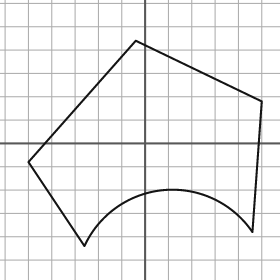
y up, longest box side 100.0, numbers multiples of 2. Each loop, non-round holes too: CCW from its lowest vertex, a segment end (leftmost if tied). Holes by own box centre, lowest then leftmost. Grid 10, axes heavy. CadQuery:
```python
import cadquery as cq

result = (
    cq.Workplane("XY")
    .moveTo(-26.0, -44.0)
    .threePointArc((8.0, -20.0), (46.0, -38.0))
    .lineTo(50.0, 18.0)
    .lineTo(-4.0, 44.0)
    .lineTo(-50.0, -8.0)
    .close()
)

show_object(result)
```